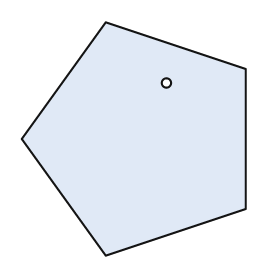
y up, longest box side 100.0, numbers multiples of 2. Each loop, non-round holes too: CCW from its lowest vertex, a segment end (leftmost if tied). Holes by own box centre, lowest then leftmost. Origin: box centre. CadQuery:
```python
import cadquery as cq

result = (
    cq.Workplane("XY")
    .moveTo(-12.0, -50.0)
    .lineTo(48.0, -30.0)
    .lineTo(48.0, 30.0)
    .lineTo(-12.0, 50.0)
    .lineTo(-48.0, 0.0)
    .close()
    .moveTo(14.0, 24.0)
    .circle(2.0)
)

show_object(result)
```